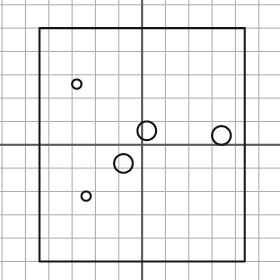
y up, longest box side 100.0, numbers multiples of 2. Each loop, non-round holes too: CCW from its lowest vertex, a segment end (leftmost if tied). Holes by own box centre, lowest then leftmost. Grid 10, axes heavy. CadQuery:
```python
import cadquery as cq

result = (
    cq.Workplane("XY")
    .moveTo(-44.0, -50.0)
    .lineTo(44.0, -50.0)
    .lineTo(44.0, 50.0)
    .lineTo(-44.0, 50.0)
    .close()
    .moveTo(-24.0, -22.0)
    .circle(2.0)
    .moveTo(-8.0, -8.0)
    .circle(4.0)
    .moveTo(34.0, 4.0)
    .circle(4.0)
    .moveTo(2.0, 6.0)
    .circle(4.0)
    .moveTo(-28.0, 26.0)
    .circle(2.0)
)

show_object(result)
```